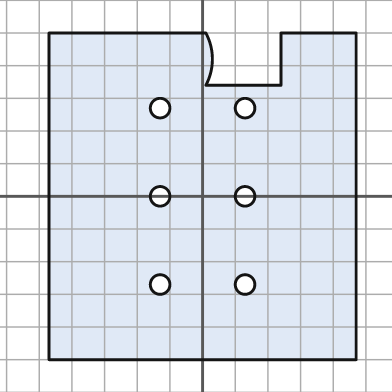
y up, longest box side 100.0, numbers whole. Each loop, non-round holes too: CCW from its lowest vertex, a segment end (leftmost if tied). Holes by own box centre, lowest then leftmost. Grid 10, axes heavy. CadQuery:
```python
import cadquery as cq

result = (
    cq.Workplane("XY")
    .moveTo(-47.0, -50.0)
    .lineTo(47.0, -50.0)
    .lineTo(47.0, 50.0)
    .lineTo(24.0, 50.0)
    .lineTo(24.0, 34.0)
    .lineTo(1.0, 34.0)
    .threePointArc((3.0, 42.0), (1.0, 50.0))
    .lineTo(-47.0, 50.0)
    .close()
    .moveTo(-13.0, -27.0)
    .circle(3.0)
    .moveTo(13.0, -27.0)
    .circle(3.0)
    .moveTo(-13.0, 0.0)
    .circle(3.0)
    .moveTo(13.0, 0.0)
    .circle(3.0)
    .moveTo(-13.0, 27.0)
    .circle(3.0)
    .moveTo(13.0, 27.0)
    .circle(3.0)
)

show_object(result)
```